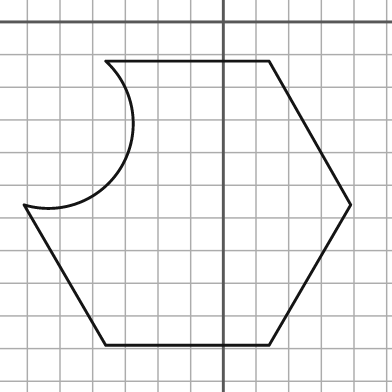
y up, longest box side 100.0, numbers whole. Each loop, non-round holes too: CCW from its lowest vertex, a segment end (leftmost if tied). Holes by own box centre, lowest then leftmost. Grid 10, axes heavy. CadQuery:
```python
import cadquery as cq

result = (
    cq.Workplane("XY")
    .moveTo(-36.0, -99.0)
    .lineTo(14.0, -99.0)
    .lineTo(39.0, -56.0)
    .lineTo(14.0, -12.0)
    .lineTo(-36.0, -12.0)
    .threePointArc((-31.0, -44.0), (-61.0, -56.0))
    .close()
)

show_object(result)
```